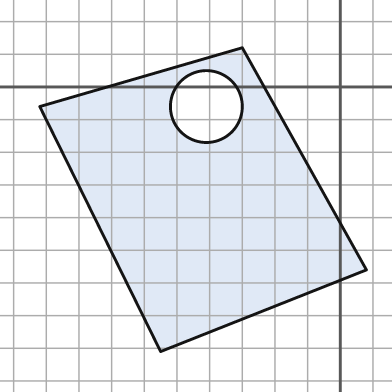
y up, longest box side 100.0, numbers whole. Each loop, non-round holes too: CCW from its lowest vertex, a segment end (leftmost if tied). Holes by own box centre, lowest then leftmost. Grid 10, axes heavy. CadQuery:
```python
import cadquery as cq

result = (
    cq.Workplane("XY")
    .moveTo(-55.0, -81.0)
    .lineTo(8.0, -56.0)
    .lineTo(-30.0, 12.0)
    .lineTo(-92.0, -6.0)
    .close()
    .moveTo(-41.0, -6.0)
    .circle(11.0)
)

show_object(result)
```